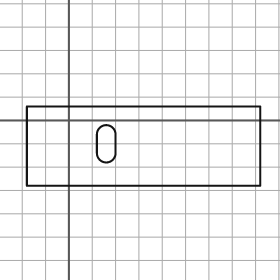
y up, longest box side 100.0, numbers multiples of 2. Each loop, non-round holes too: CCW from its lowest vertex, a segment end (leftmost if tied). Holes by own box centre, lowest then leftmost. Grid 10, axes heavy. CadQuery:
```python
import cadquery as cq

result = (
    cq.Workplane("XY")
    .moveTo(-18.0, -28.0)
    .lineTo(82.0, -28.0)
    .lineTo(82.0, 6.0)
    .lineTo(-18.0, 6.0)
    .close()
    .moveTo(12.0, -14.0)
    .threePointArc((16.0, -18.0), (20.0, -14.0))
    .lineTo(20.0, -6.0)
    .threePointArc((16.0, -2.0), (12.0, -6.0))
    .close()
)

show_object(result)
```